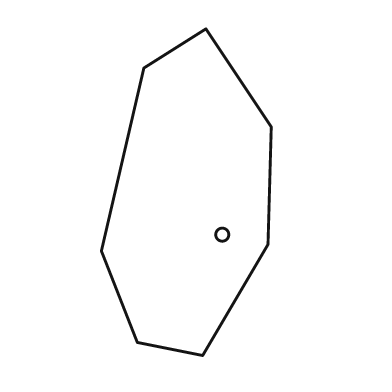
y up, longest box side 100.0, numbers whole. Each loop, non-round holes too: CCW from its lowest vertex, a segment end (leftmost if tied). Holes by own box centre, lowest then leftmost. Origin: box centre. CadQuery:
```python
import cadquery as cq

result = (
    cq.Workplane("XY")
    .moveTo(5.0, -50.0)
    .lineTo(25.0, -16.0)
    .lineTo(26.0, 20.0)
    .lineTo(6.0, 50.0)
    .lineTo(-13.0, 38.0)
    .lineTo(-26.0, -18.0)
    .lineTo(-15.0, -46.0)
    .close()
    .moveTo(11.0, -13.0)
    .circle(2.0)
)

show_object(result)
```